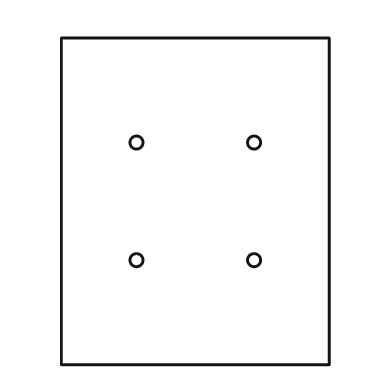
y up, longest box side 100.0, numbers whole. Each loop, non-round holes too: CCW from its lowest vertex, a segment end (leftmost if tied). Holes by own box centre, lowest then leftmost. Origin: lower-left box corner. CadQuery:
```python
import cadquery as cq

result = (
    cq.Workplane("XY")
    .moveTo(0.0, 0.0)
    .lineTo(82.0, 0.0)
    .lineTo(82.0, 100.0)
    .lineTo(0.0, 100.0)
    .close()
    .moveTo(23.0, 32.0)
    .circle(2.0)
    .moveTo(59.0, 32.0)
    .circle(2.0)
    .moveTo(23.0, 68.0)
    .circle(2.0)
    .moveTo(59.0, 68.0)
    .circle(2.0)
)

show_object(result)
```